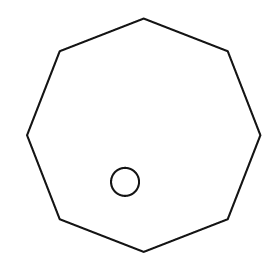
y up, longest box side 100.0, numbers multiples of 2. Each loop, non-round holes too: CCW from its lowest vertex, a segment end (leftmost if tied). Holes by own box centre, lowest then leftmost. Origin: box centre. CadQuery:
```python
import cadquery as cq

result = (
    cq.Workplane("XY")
    .moveTo(0.0, -50.0)
    .lineTo(36.0, -36.0)
    .lineTo(50.0, 0.0)
    .lineTo(36.0, 36.0)
    .lineTo(0.0, 50.0)
    .lineTo(-36.0, 36.0)
    .lineTo(-50.0, 0.0)
    .lineTo(-36.0, -36.0)
    .close()
    .moveTo(-8.0, -20.0)
    .circle(6.0)
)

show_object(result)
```